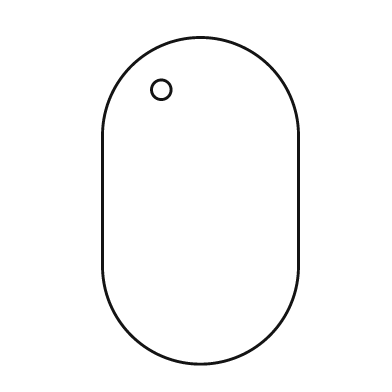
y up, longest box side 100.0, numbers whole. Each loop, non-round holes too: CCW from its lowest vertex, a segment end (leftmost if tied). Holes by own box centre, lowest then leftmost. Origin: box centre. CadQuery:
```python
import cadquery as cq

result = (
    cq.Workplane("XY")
    .moveTo(-30.0, -20.0)
    .threePointArc((0.0, -50.0), (30.0, -20.0))
    .lineTo(30.0, 20.0)
    .threePointArc((0.0, 50.0), (-30.0, 20.0))
    .close()
    .moveTo(-12.0, 34.0)
    .circle(3.0)
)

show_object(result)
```